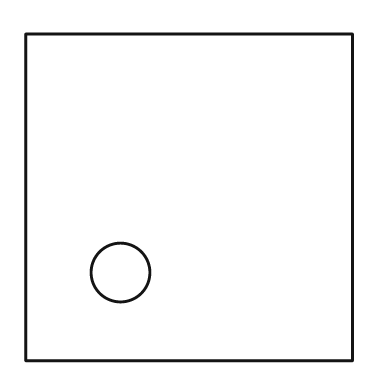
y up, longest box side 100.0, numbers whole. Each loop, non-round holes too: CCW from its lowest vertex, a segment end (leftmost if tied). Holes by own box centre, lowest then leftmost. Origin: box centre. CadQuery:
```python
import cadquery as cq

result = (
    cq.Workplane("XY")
    .moveTo(-50.0, -50.0)
    .lineTo(50.0, -50.0)
    .lineTo(50.0, 50.0)
    .lineTo(-50.0, 50.0)
    .close()
    .moveTo(-21.0, -23.0)
    .circle(9.0)
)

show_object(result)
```